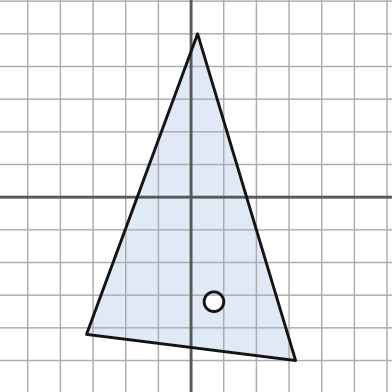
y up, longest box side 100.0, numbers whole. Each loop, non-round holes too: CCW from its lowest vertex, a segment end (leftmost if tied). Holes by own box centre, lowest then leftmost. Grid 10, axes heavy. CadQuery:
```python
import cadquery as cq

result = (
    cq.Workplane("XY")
    .moveTo(32.0, -50.0)
    .lineTo(2.0, 50.0)
    .lineTo(-32.0, -42.0)
    .close()
    .moveTo(7.0, -32.0)
    .circle(3.0)
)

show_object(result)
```